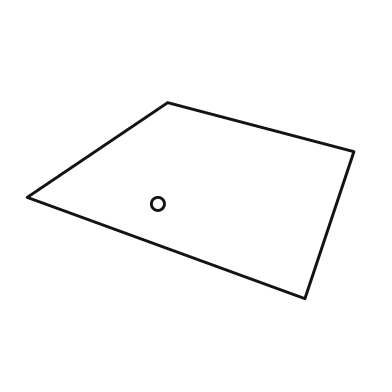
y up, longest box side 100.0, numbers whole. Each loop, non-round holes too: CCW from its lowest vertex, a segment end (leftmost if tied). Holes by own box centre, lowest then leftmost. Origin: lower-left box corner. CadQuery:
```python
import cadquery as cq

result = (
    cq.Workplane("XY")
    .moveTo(85.0, 0.0)
    .lineTo(100.0, 45.0)
    .lineTo(43.0, 60.0)
    .lineTo(0.0, 31.0)
    .close()
    .moveTo(40.0, 29.0)
    .circle(2.0)
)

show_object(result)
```